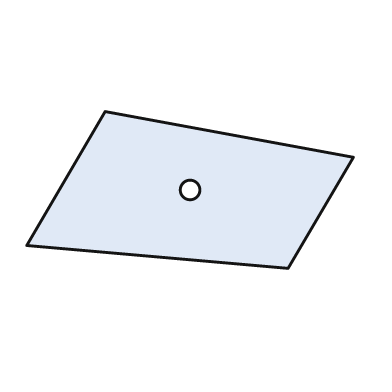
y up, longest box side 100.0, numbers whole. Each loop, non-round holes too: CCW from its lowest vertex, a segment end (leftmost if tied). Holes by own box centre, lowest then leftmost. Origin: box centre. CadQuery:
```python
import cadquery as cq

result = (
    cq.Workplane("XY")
    .moveTo(30.0, -24.0)
    .lineTo(50.0, 10.0)
    .lineTo(-26.0, 24.0)
    .lineTo(-50.0, -17.0)
    .close()
    .moveTo(0.0, 0.0)
    .circle(3.0)
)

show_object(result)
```